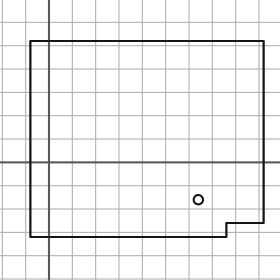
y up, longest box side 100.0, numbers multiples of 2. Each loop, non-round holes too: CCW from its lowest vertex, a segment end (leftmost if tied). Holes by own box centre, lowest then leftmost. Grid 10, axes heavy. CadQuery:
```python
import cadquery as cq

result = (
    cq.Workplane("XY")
    .moveTo(-8.0, -32.0)
    .lineTo(76.0, -32.0)
    .lineTo(76.0, -26.0)
    .lineTo(92.0, -26.0)
    .lineTo(92.0, 52.0)
    .lineTo(-8.0, 52.0)
    .close()
    .moveTo(64.0, -16.0)
    .circle(2.0)
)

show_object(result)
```